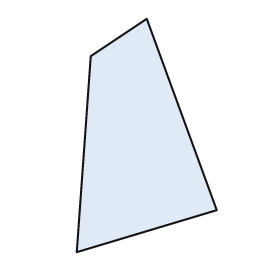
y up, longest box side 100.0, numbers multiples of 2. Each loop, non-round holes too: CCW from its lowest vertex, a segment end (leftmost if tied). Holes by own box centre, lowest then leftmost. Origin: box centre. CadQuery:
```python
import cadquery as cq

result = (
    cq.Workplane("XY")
    .moveTo(-30.0, -50.0)
    .lineTo(30.0, -32.0)
    .lineTo(0.0, 50.0)
    .lineTo(-24.0, 34.0)
    .close()
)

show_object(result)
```